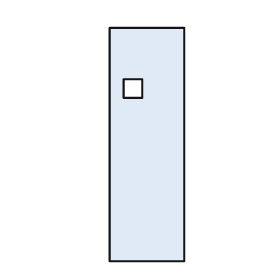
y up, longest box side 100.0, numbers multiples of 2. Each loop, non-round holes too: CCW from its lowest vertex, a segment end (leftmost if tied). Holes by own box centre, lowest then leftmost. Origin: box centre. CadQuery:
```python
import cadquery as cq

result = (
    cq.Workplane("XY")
    .moveTo(-16.0, -50.0)
    .lineTo(16.0, -50.0)
    .lineTo(16.0, 50.0)
    .lineTo(-16.0, 50.0)
    .close()
    .moveTo(-10.0, 20.0)
    .lineTo(-2.0, 20.0)
    .lineTo(-2.0, 28.0)
    .lineTo(-10.0, 28.0)
    .close()
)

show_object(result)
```